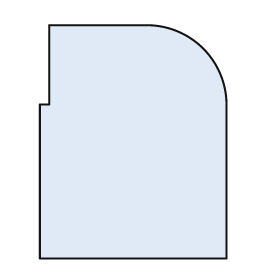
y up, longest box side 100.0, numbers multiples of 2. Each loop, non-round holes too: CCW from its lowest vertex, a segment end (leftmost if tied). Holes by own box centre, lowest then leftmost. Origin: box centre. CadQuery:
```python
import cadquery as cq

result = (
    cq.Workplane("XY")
    .moveTo(-40.0, -50.0)
    .lineTo(40.0, -50.0)
    .lineTo(40.0, 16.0)
    .threePointArc((30.0, 40.0), (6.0, 50.0))
    .lineTo(-36.0, 50.0)
    .lineTo(-36.0, 16.0)
    .lineTo(-40.0, 16.0)
    .close()
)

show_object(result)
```